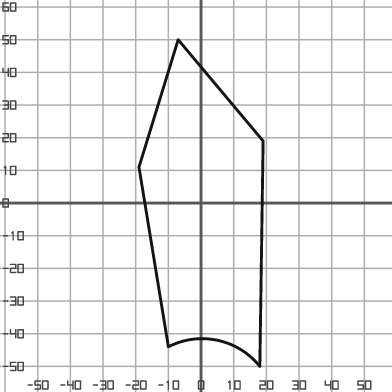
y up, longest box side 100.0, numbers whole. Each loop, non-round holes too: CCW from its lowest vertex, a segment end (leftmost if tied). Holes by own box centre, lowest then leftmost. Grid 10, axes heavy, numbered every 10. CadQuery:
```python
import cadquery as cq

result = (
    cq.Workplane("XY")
    .moveTo(18.0, -50.0)
    .lineTo(19.0, 19.0)
    .lineTo(-7.0, 50.0)
    .lineTo(-19.0, 11.0)
    .lineTo(-10.0, -44.0)
    .threePointArc((5.0, -42.0), (18.0, -50.0))
    .close()
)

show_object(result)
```